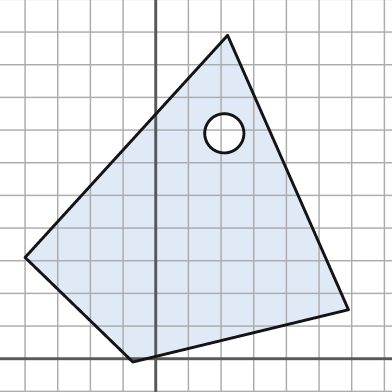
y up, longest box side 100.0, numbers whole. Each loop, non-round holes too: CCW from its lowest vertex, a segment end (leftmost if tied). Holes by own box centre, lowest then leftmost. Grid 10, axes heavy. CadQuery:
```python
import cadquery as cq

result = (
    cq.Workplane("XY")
    .moveTo(-7.0, -1.0)
    .lineTo(59.0, 15.0)
    .lineTo(22.0, 99.0)
    .lineTo(-40.0, 31.0)
    .close()
    .moveTo(21.0, 69.0)
    .circle(6.0)
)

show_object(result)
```